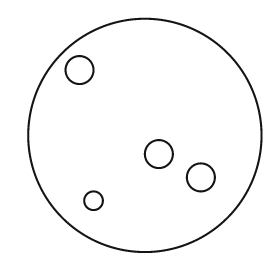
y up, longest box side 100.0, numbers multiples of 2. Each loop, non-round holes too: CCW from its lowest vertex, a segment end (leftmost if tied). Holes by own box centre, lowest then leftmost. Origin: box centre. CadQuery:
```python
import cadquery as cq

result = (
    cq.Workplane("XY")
    .moveTo(0.0, 0.0)
    .circle(50.0)
    .moveTo(-22.0, -28.0)
    .circle(4.0)
    .moveTo(24.0, -18.0)
    .circle(6.0)
    .moveTo(6.0, -8.0)
    .circle(6.0)
    .moveTo(-28.0, 28.0)
    .circle(6.0)
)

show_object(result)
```